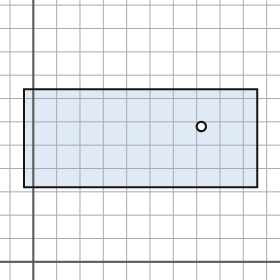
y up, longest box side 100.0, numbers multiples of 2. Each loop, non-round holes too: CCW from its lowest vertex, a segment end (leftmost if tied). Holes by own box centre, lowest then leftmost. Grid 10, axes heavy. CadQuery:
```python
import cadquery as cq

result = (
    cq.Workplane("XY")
    .moveTo(-4.0, 32.0)
    .lineTo(96.0, 32.0)
    .lineTo(96.0, 74.0)
    .lineTo(-4.0, 74.0)
    .close()
    .moveTo(72.0, 58.0)
    .circle(2.0)
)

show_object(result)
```